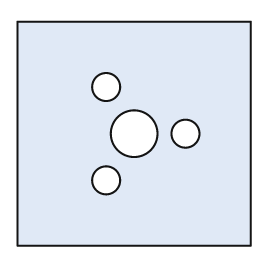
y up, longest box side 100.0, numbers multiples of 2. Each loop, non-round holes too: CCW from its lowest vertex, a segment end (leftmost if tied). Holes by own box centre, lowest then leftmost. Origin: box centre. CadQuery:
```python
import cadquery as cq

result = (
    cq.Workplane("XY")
    .moveTo(-50.0, -48.0)
    .lineTo(50.0, -48.0)
    .lineTo(50.0, 48.0)
    .lineTo(-50.0, 48.0)
    .close()
    .moveTo(-12.0, -20.0)
    .circle(6.0)
    .moveTo(0.0, 0.0)
    .circle(10.0)
    .moveTo(22.0, 0.0)
    .circle(6.0)
    .moveTo(-12.0, 20.0)
    .circle(6.0)
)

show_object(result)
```